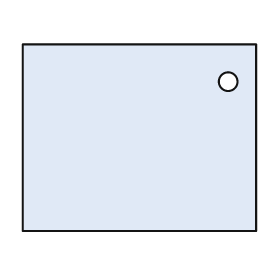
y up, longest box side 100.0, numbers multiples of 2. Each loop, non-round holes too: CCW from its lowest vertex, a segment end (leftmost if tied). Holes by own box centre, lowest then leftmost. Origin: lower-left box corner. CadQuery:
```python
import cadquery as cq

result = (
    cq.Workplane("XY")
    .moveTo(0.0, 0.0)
    .lineTo(100.0, 0.0)
    .lineTo(100.0, 80.0)
    .lineTo(0.0, 80.0)
    .close()
    .moveTo(88.0, 64.0)
    .circle(4.0)
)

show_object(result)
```